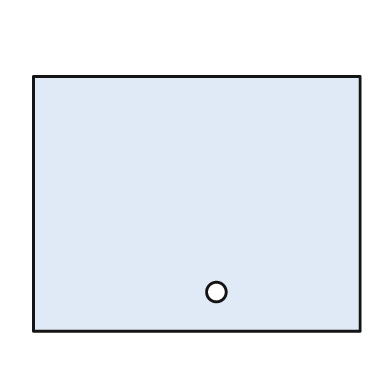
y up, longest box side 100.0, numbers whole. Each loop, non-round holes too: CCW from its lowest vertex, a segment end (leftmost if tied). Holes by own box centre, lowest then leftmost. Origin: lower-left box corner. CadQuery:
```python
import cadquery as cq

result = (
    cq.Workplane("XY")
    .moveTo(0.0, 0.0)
    .lineTo(100.0, 0.0)
    .lineTo(100.0, 78.0)
    .lineTo(0.0, 78.0)
    .close()
    .moveTo(56.0, 12.0)
    .circle(3.0)
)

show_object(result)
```